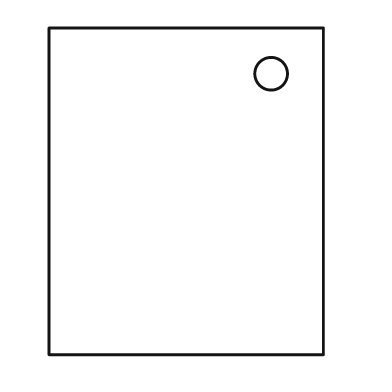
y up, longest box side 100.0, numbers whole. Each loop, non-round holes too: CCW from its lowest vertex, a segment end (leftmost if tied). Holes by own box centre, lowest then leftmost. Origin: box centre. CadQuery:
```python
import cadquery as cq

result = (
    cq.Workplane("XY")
    .moveTo(-42.0, -50.0)
    .lineTo(42.0, -50.0)
    .lineTo(42.0, 50.0)
    .lineTo(-42.0, 50.0)
    .close()
    .moveTo(26.0, 36.0)
    .circle(5.0)
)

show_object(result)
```